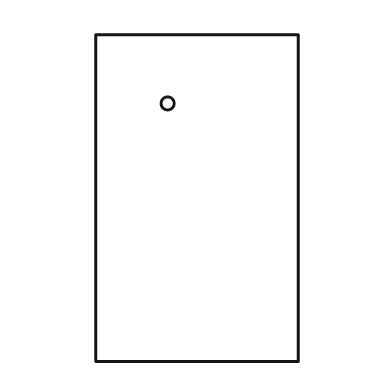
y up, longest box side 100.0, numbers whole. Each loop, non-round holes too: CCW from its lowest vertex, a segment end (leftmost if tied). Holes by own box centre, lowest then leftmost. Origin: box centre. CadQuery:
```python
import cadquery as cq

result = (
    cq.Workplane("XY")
    .moveTo(-31.0, -50.0)
    .lineTo(31.0, -50.0)
    .lineTo(31.0, 50.0)
    .lineTo(-31.0, 50.0)
    .close()
    .moveTo(-9.0, 29.0)
    .circle(2.0)
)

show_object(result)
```